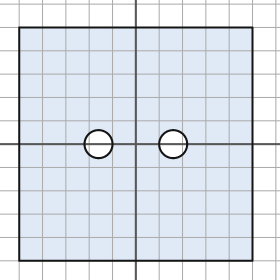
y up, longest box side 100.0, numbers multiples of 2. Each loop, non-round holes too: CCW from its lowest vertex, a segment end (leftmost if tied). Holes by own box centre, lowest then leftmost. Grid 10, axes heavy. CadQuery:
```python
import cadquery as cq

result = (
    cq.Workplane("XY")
    .moveTo(-50.0, -50.0)
    .lineTo(50.0, -50.0)
    .lineTo(50.0, 50.0)
    .lineTo(-50.0, 50.0)
    .close()
    .moveTo(-16.0, 0.0)
    .circle(6.0)
    .moveTo(16.0, 0.0)
    .circle(6.0)
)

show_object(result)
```